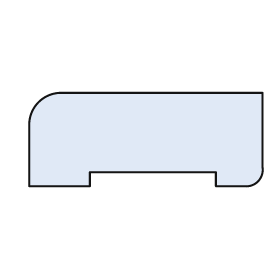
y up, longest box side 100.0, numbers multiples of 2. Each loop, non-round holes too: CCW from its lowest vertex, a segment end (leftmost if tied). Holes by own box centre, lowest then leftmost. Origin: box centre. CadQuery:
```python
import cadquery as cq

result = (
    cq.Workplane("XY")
    .moveTo(-50.0, -20.0)
    .lineTo(-24.0, -20.0)
    .lineTo(-24.0, -14.0)
    .lineTo(30.0, -14.0)
    .lineTo(30.0, -20.0)
    .lineTo(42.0, -20.0)
    .threePointArc((48.0, -18.0), (50.0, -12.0))
    .lineTo(50.0, 20.0)
    .lineTo(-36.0, 20.0)
    .threePointArc((-46.0, 16.0), (-50.0, 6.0))
    .close()
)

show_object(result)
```